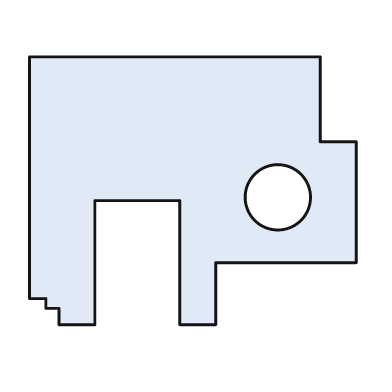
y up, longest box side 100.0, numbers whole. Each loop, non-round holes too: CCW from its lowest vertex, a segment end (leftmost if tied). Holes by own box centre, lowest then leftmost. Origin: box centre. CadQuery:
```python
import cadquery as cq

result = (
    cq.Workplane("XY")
    .moveTo(-41.0, -41.0)
    .lineTo(-30.0, -41.0)
    .lineTo(-30.0, -3.0)
    .lineTo(-4.0, -3.0)
    .lineTo(-4.0, -41.0)
    .lineTo(7.0, -41.0)
    .lineTo(7.0, -22.0)
    .lineTo(50.0, -22.0)
    .lineTo(50.0, 15.0)
    .lineTo(39.0, 15.0)
    .lineTo(39.0, 41.0)
    .lineTo(-50.0, 41.0)
    .lineTo(-50.0, -33.0)
    .lineTo(-45.0, -33.0)
    .lineTo(-45.0, -36.0)
    .lineTo(-41.0, -36.0)
    .close()
    .moveTo(26.0, -2.0)
    .circle(10.0)
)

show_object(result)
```